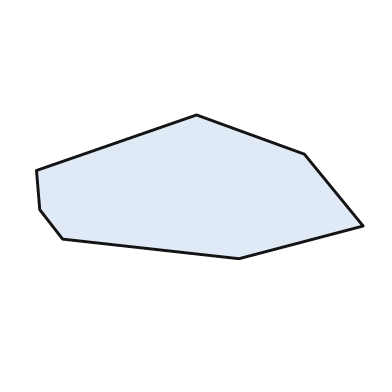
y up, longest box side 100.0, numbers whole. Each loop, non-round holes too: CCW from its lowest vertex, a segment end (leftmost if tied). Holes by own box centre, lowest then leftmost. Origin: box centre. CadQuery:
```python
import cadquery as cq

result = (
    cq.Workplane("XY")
    .moveTo(12.0, -22.0)
    .lineTo(50.0, -12.0)
    .lineTo(32.0, 10.0)
    .lineTo(-1.0, 22.0)
    .lineTo(-50.0, 5.0)
    .lineTo(-49.0, -7.0)
    .lineTo(-42.0, -16.0)
    .close()
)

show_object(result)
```